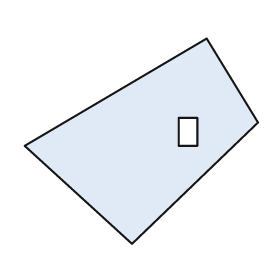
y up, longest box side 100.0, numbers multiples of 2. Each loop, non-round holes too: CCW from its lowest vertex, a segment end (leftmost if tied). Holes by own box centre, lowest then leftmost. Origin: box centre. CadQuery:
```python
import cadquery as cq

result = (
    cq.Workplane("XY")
    .moveTo(-4.0, -44.0)
    .lineTo(50.0, 8.0)
    .lineTo(28.0, 44.0)
    .lineTo(-50.0, -2.0)
    .close()
    .moveTo(16.0, -2.0)
    .lineTo(24.0, -2.0)
    .lineTo(24.0, 10.0)
    .lineTo(16.0, 10.0)
    .close()
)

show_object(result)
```